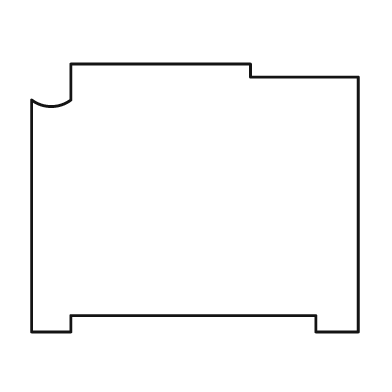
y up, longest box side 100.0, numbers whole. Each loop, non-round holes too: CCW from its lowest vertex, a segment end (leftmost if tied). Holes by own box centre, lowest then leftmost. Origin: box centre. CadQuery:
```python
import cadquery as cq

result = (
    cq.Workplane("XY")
    .moveTo(-50.0, -41.0)
    .lineTo(-38.0, -41.0)
    .lineTo(-38.0, -36.0)
    .lineTo(37.0, -36.0)
    .lineTo(37.0, -41.0)
    .lineTo(50.0, -41.0)
    .lineTo(50.0, 37.0)
    .lineTo(17.0, 37.0)
    .lineTo(17.0, 41.0)
    .lineTo(-38.0, 41.0)
    .lineTo(-38.0, 30.0)
    .threePointArc((-44.0, 28.0), (-50.0, 30.0))
    .close()
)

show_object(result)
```